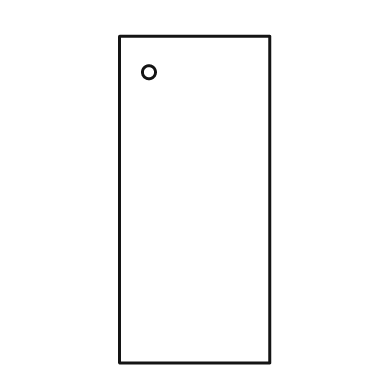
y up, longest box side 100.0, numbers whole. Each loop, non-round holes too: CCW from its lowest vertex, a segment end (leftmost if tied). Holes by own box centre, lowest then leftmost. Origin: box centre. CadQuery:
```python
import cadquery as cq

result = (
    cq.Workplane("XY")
    .moveTo(-23.0, -50.0)
    .lineTo(23.0, -50.0)
    .lineTo(23.0, 50.0)
    .lineTo(-23.0, 50.0)
    .close()
    .moveTo(-14.0, 39.0)
    .circle(2.0)
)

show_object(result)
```